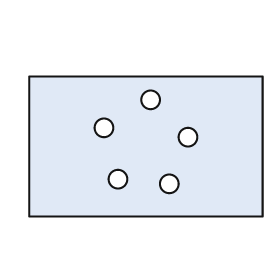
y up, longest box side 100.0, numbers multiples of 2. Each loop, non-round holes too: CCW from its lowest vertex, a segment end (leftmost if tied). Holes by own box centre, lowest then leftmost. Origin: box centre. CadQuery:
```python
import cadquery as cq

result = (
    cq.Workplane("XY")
    .moveTo(-50.0, -30.0)
    .lineTo(50.0, -30.0)
    .lineTo(50.0, 30.0)
    .lineTo(-50.0, 30.0)
    .close()
    .moveTo(10.0, -16.0)
    .circle(4.0)
    .moveTo(-12.0, -14.0)
    .circle(4.0)
    .moveTo(18.0, 4.0)
    .circle(4.0)
    .moveTo(-18.0, 8.0)
    .circle(4.0)
    .moveTo(2.0, 20.0)
    .circle(4.0)
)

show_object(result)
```